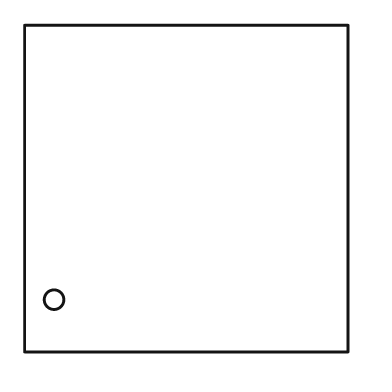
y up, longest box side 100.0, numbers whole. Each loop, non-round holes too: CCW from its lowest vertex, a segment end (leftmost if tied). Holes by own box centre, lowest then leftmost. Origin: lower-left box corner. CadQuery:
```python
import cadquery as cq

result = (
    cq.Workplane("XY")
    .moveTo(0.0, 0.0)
    .lineTo(99.0, 0.0)
    .lineTo(99.0, 100.0)
    .lineTo(0.0, 100.0)
    .close()
    .moveTo(9.0, 16.0)
    .circle(3.0)
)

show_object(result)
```